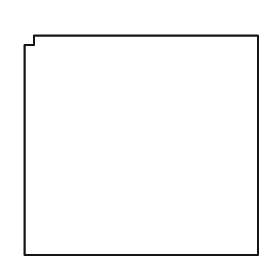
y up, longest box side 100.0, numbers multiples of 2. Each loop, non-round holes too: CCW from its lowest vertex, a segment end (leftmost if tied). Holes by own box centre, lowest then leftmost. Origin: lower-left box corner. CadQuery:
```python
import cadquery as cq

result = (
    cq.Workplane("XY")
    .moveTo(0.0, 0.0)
    .lineTo(100.0, 0.0)
    .lineTo(100.0, 94.0)
    .lineTo(4.0, 94.0)
    .lineTo(4.0, 90.0)
    .lineTo(0.0, 90.0)
    .close()
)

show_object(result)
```